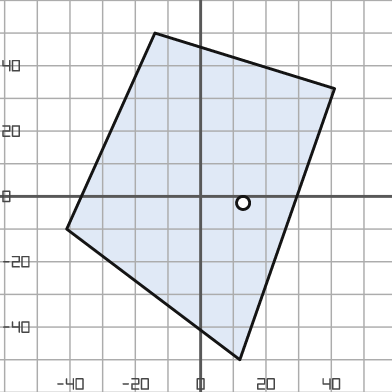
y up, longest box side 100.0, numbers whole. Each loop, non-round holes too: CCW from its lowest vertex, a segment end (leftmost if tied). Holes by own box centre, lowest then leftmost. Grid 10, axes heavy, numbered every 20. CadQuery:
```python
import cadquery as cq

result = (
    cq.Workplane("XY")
    .moveTo(12.0, -50.0)
    .lineTo(41.0, 33.0)
    .lineTo(-14.0, 50.0)
    .lineTo(-41.0, -10.0)
    .close()
    .moveTo(13.0, -2.0)
    .circle(2.0)
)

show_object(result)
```